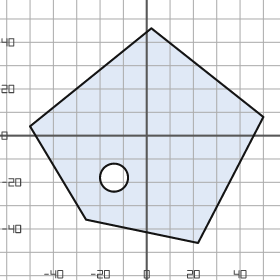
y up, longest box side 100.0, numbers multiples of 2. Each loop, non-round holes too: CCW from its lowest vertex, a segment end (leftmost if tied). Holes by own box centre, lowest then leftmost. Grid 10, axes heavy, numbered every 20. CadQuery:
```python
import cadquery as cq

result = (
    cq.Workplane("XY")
    .moveTo(22.0, -46.0)
    .lineTo(50.0, 8.0)
    .lineTo(2.0, 46.0)
    .lineTo(-50.0, 4.0)
    .lineTo(-26.0, -36.0)
    .close()
    .moveTo(-14.0, -18.0)
    .circle(6.0)
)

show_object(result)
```